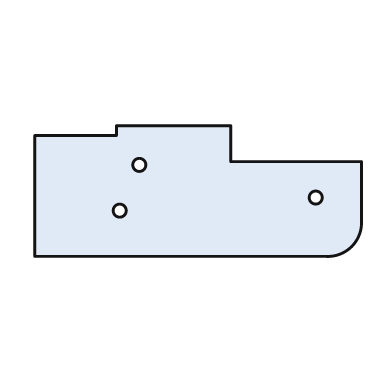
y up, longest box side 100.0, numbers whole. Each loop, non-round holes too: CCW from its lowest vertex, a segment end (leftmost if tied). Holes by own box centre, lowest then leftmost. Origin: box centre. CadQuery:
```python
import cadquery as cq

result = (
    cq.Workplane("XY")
    .moveTo(-50.0, -20.0)
    .lineTo(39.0, -20.0)
    .threePointArc((47.0, -17.0), (50.0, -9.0))
    .lineTo(50.0, 9.0)
    .lineTo(10.0, 9.0)
    .lineTo(10.0, 20.0)
    .lineTo(-25.0, 20.0)
    .lineTo(-25.0, 17.0)
    .lineTo(-50.0, 17.0)
    .close()
    .moveTo(-24.0, -6.0)
    .circle(2.0)
    .moveTo(36.0, -2.0)
    .circle(2.0)
    .moveTo(-18.0, 8.0)
    .circle(2.0)
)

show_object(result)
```